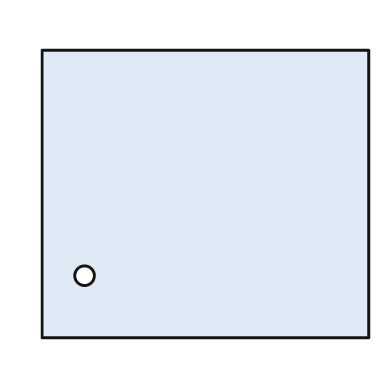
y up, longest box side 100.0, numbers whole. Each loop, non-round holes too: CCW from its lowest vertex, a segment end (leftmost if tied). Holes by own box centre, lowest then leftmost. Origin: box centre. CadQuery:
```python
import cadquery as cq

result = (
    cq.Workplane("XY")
    .moveTo(-50.0, -44.0)
    .lineTo(50.0, -44.0)
    .lineTo(50.0, 44.0)
    .lineTo(-50.0, 44.0)
    .close()
    .moveTo(-37.0, -25.0)
    .circle(3.0)
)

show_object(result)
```